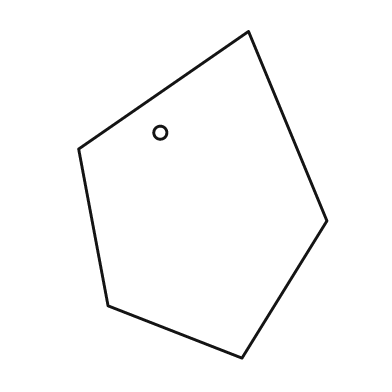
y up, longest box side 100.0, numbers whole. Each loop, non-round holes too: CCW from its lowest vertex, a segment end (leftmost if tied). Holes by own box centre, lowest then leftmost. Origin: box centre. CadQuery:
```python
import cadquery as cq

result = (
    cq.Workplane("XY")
    .moveTo(12.0, -50.0)
    .lineTo(38.0, -8.0)
    .lineTo(14.0, 50.0)
    .lineTo(-38.0, 14.0)
    .lineTo(-29.0, -34.0)
    .close()
    .moveTo(-13.0, 19.0)
    .circle(2.0)
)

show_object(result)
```